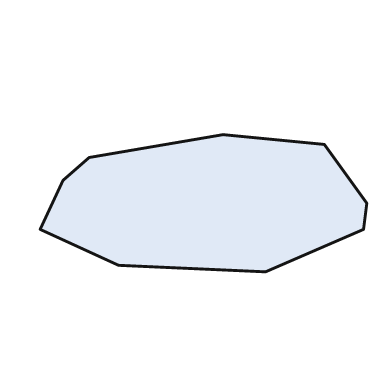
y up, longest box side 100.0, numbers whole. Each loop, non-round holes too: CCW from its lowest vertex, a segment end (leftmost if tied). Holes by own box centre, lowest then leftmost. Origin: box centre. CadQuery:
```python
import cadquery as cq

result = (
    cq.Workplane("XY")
    .moveTo(19.0, -21.0)
    .lineTo(49.0, -8.0)
    .lineTo(50.0, 0.0)
    .lineTo(37.0, 18.0)
    .lineTo(6.0, 21.0)
    .lineTo(-35.0, 14.0)
    .lineTo(-43.0, 7.0)
    .lineTo(-50.0, -8.0)
    .lineTo(-26.0, -19.0)
    .close()
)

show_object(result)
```